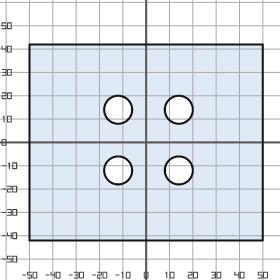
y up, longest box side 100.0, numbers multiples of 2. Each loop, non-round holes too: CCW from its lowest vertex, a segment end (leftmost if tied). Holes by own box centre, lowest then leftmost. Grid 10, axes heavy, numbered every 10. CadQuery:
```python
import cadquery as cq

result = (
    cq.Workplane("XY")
    .moveTo(-50.0, -42.0)
    .lineTo(50.0, -42.0)
    .lineTo(50.0, 42.0)
    .lineTo(-50.0, 42.0)
    .close()
    .moveTo(-12.0, -12.0)
    .circle(6.0)
    .moveTo(14.0, -12.0)
    .circle(6.0)
    .moveTo(-12.0, 14.0)
    .circle(6.0)
    .moveTo(14.0, 14.0)
    .circle(6.0)
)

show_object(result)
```